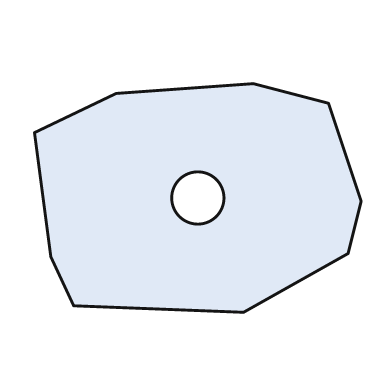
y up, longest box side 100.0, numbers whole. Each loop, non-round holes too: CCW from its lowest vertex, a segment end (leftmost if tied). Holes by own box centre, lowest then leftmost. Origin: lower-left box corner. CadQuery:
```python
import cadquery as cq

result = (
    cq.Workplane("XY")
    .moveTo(64.0, 0.0)
    .lineTo(96.0, 18.0)
    .lineTo(100.0, 34.0)
    .lineTo(90.0, 64.0)
    .lineTo(67.0, 70.0)
    .lineTo(25.0, 67.0)
    .lineTo(0.0, 55.0)
    .lineTo(5.0, 17.0)
    .lineTo(12.0, 2.0)
    .close()
    .moveTo(50.0, 35.0)
    .circle(8.0)
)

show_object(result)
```